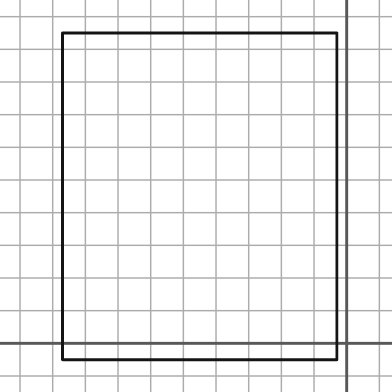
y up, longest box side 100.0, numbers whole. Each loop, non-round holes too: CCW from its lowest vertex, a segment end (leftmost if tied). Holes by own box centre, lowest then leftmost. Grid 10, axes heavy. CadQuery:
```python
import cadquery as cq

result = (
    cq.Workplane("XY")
    .moveTo(-87.0, -5.0)
    .lineTo(-3.0, -5.0)
    .lineTo(-3.0, 95.0)
    .lineTo(-87.0, 95.0)
    .close()
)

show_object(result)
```